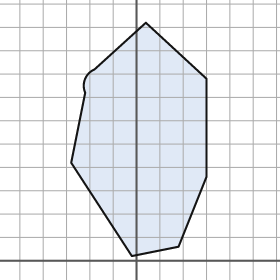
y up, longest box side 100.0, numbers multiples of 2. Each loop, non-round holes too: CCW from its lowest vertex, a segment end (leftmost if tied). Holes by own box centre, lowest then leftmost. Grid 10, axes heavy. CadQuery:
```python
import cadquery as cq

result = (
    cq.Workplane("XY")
    .moveTo(-2.0, 2.0)
    .lineTo(18.0, 6.0)
    .lineTo(30.0, 36.0)
    .lineTo(30.0, 78.0)
    .lineTo(4.0, 102.0)
    .lineTo(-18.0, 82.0)
    .threePointArc((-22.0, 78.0), (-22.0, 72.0))
    .lineTo(-28.0, 42.0)
    .close()
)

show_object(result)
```